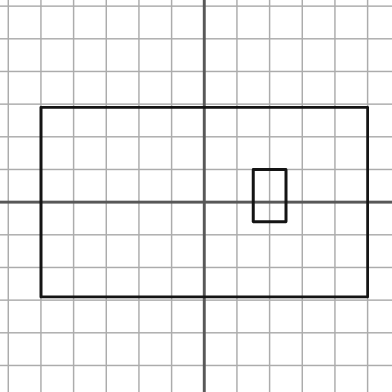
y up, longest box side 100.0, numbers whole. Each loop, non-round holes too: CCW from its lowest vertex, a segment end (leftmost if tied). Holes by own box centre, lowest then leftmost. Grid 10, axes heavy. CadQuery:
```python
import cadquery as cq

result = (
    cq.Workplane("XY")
    .moveTo(-50.0, -29.0)
    .lineTo(50.0, -29.0)
    .lineTo(50.0, 29.0)
    .lineTo(-50.0, 29.0)
    .close()
    .moveTo(15.0, -6.0)
    .lineTo(25.0, -6.0)
    .lineTo(25.0, 10.0)
    .lineTo(15.0, 10.0)
    .close()
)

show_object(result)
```